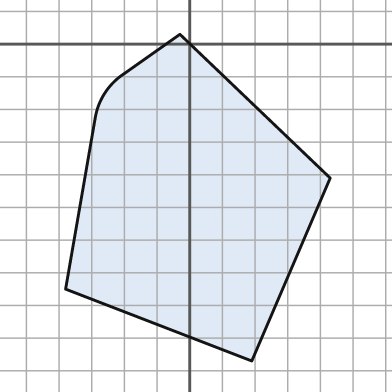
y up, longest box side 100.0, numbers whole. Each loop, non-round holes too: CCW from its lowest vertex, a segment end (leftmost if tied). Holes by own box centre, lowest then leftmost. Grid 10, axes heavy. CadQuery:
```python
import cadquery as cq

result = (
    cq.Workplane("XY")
    .moveTo(19.0, -97.0)
    .lineTo(43.0, -41.0)
    .lineTo(-3.0, 3.0)
    .lineTo(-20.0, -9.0)
    .threePointArc((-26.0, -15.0), (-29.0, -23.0))
    .lineTo(-38.0, -75.0)
    .close()
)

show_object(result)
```